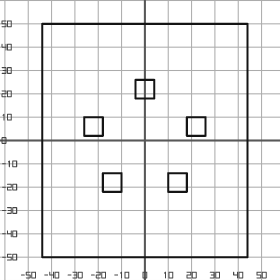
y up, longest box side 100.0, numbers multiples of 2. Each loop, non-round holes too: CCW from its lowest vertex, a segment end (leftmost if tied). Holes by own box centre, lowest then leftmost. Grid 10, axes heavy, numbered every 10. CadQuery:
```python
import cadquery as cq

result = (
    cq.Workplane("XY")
    .moveTo(-44.0, -50.0)
    .lineTo(44.0, -50.0)
    .lineTo(44.0, 50.0)
    .lineTo(-44.0, 50.0)
    .close()
    .moveTo(-18.0, -22.0)
    .lineTo(-10.0, -22.0)
    .lineTo(-10.0, -14.0)
    .lineTo(-18.0, -14.0)
    .close()
    .moveTo(10.0, -22.0)
    .lineTo(18.0, -22.0)
    .lineTo(18.0, -14.0)
    .lineTo(10.0, -14.0)
    .close()
    .moveTo(-26.0, 2.0)
    .lineTo(-18.0, 2.0)
    .lineTo(-18.0, 10.0)
    .lineTo(-26.0, 10.0)
    .close()
    .moveTo(18.0, 2.0)
    .lineTo(26.0, 2.0)
    .lineTo(26.0, 10.0)
    .lineTo(18.0, 10.0)
    .close()
    .moveTo(-4.0, 18.0)
    .lineTo(4.0, 18.0)
    .lineTo(4.0, 26.0)
    .lineTo(-4.0, 26.0)
    .close()
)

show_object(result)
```